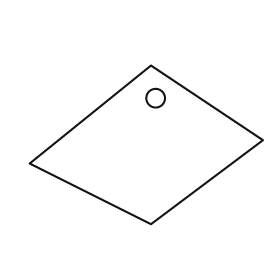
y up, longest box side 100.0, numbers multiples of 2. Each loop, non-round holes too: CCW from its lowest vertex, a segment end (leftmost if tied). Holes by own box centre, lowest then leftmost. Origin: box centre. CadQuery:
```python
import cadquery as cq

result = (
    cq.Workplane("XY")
    .moveTo(2.0, -34.0)
    .lineTo(50.0, 2.0)
    .lineTo(2.0, 34.0)
    .lineTo(-50.0, -8.0)
    .close()
    .moveTo(4.0, 20.0)
    .circle(4.0)
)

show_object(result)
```